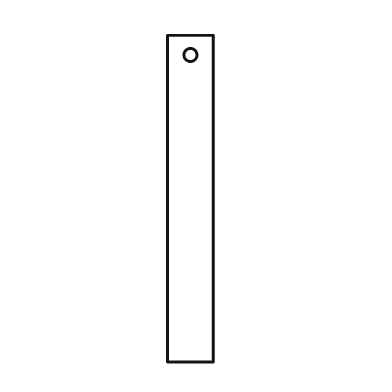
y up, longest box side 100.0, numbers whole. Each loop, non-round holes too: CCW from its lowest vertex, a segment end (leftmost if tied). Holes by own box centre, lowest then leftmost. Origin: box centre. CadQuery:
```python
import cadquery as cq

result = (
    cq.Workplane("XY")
    .moveTo(-7.0, -50.0)
    .lineTo(7.0, -50.0)
    .lineTo(7.0, 50.0)
    .lineTo(-7.0, 50.0)
    .close()
    .moveTo(0.0, 44.0)
    .circle(2.0)
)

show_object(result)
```